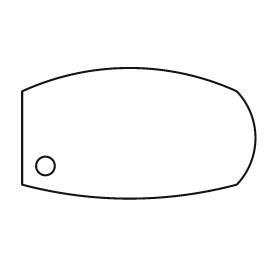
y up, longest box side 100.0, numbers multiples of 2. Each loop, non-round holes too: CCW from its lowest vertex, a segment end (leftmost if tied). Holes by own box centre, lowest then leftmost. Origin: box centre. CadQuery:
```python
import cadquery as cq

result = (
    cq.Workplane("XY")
    .moveTo(-50.0, -22.0)
    .threePointArc((-4.0, -28.0), (42.0, -22.0))
    .threePointArc((50.0, -2.0), (42.0, 18.0))
    .threePointArc((-4.0, 28.0), (-50.0, 18.0))
    .close()
    .moveTo(-40.0, -14.0)
    .circle(4.0)
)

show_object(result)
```